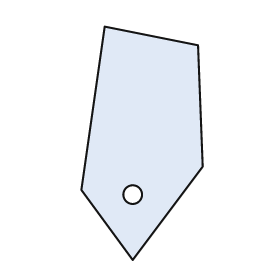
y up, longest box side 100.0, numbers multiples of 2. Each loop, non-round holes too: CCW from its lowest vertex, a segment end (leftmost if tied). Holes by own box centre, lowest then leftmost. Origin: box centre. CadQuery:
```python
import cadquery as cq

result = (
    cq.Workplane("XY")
    .moveTo(-4.0, -50.0)
    .lineTo(26.0, -10.0)
    .lineTo(24.0, 42.0)
    .lineTo(-16.0, 50.0)
    .lineTo(-26.0, -20.0)
    .close()
    .moveTo(-4.0, -22.0)
    .circle(4.0)
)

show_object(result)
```